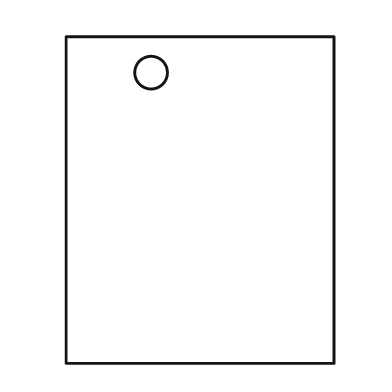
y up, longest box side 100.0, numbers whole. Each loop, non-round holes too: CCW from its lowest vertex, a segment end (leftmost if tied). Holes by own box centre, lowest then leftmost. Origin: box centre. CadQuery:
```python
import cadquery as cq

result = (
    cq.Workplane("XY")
    .moveTo(-41.0, -50.0)
    .lineTo(41.0, -50.0)
    .lineTo(41.0, 50.0)
    .lineTo(-41.0, 50.0)
    .close()
    .moveTo(-15.0, 39.0)
    .circle(5.0)
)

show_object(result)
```